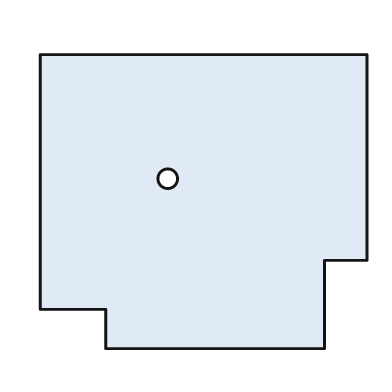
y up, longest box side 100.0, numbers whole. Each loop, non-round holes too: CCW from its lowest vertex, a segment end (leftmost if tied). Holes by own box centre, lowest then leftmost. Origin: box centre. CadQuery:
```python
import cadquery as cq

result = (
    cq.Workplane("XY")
    .moveTo(-30.0, -45.0)
    .lineTo(37.0, -45.0)
    .lineTo(37.0, -18.0)
    .lineTo(50.0, -18.0)
    .lineTo(50.0, 45.0)
    .lineTo(-50.0, 45.0)
    .lineTo(-50.0, -33.0)
    .lineTo(-30.0, -33.0)
    .close()
    .moveTo(-11.0, 7.0)
    .circle(3.0)
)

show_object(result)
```